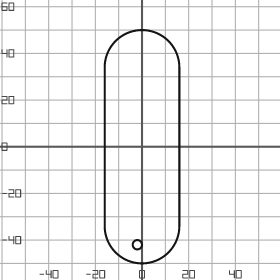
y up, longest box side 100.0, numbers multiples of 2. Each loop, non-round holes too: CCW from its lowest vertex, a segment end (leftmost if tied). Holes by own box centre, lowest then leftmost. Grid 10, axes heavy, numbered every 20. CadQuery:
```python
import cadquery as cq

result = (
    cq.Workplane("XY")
    .moveTo(-16.0, -34.0)
    .threePointArc((0.0, -50.0), (16.0, -34.0))
    .lineTo(16.0, 34.0)
    .threePointArc((0.0, 50.0), (-16.0, 34.0))
    .close()
    .moveTo(-2.0, -42.0)
    .circle(2.0)
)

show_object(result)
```